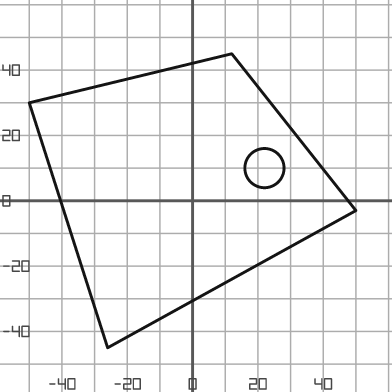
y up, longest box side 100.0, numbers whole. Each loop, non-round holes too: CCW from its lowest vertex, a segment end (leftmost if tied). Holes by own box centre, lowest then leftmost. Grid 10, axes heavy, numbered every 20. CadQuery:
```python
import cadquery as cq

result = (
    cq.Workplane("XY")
    .moveTo(-26.0, -45.0)
    .lineTo(50.0, -3.0)
    .lineTo(12.0, 45.0)
    .lineTo(-50.0, 30.0)
    .close()
    .moveTo(22.0, 10.0)
    .circle(6.0)
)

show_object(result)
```